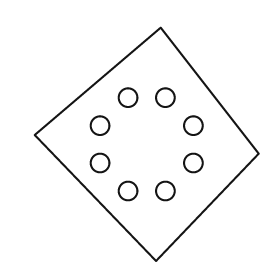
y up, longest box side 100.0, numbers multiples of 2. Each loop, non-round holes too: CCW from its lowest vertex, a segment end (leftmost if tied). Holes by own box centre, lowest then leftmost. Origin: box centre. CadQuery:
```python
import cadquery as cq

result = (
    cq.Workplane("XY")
    .moveTo(4.0, -50.0)
    .lineTo(48.0, -4.0)
    .lineTo(6.0, 50.0)
    .lineTo(-48.0, 4.0)
    .close()
    .moveTo(-8.0, -20.0)
    .circle(4.0)
    .moveTo(8.0, -20.0)
    .circle(4.0)
    .moveTo(-20.0, -8.0)
    .circle(4.0)
    .moveTo(20.0, -8.0)
    .circle(4.0)
    .moveTo(-20.0, 8.0)
    .circle(4.0)
    .moveTo(20.0, 8.0)
    .circle(4.0)
    .moveTo(-8.0, 20.0)
    .circle(4.0)
    .moveTo(8.0, 20.0)
    .circle(4.0)
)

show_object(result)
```